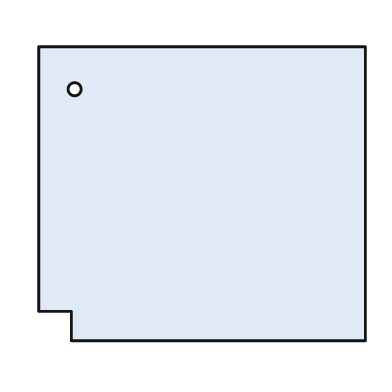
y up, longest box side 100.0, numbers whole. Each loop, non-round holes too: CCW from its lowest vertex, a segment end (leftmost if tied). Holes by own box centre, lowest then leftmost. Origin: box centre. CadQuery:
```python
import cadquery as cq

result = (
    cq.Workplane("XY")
    .moveTo(-40.0, -45.0)
    .lineTo(50.0, -45.0)
    .lineTo(50.0, 45.0)
    .lineTo(-50.0, 45.0)
    .lineTo(-50.0, -36.0)
    .lineTo(-40.0, -36.0)
    .close()
    .moveTo(-39.0, 32.0)
    .circle(2.0)
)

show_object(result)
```